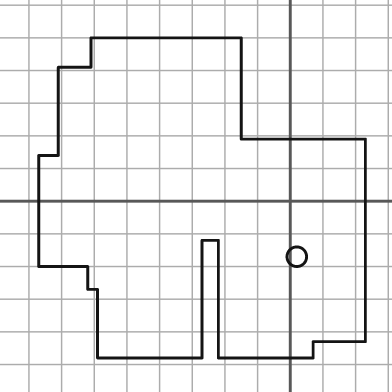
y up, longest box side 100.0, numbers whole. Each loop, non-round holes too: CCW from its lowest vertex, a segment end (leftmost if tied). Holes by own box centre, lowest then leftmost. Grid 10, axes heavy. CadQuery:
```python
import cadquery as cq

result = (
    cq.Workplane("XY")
    .moveTo(-59.0, -48.0)
    .lineTo(-27.0, -48.0)
    .lineTo(-27.0, -12.0)
    .lineTo(-22.0, -12.0)
    .lineTo(-22.0, -48.0)
    .lineTo(7.0, -48.0)
    .lineTo(7.0, -43.0)
    .lineTo(23.0, -43.0)
    .lineTo(23.0, 19.0)
    .lineTo(-15.0, 19.0)
    .lineTo(-15.0, 50.0)
    .lineTo(-61.0, 50.0)
    .lineTo(-61.0, 41.0)
    .lineTo(-71.0, 41.0)
    .lineTo(-71.0, 14.0)
    .lineTo(-77.0, 14.0)
    .lineTo(-77.0, -20.0)
    .lineTo(-62.0, -20.0)
    .lineTo(-62.0, -27.0)
    .lineTo(-59.0, -27.0)
    .close()
    .moveTo(2.0, -17.0)
    .circle(3.0)
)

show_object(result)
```